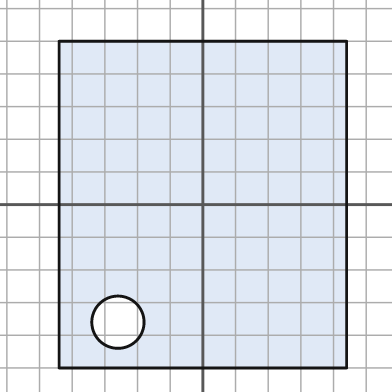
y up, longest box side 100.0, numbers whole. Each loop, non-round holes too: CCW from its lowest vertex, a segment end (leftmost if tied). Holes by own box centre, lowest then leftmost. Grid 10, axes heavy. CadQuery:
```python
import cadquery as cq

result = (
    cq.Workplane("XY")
    .moveTo(-44.0, -50.0)
    .lineTo(44.0, -50.0)
    .lineTo(44.0, 50.0)
    .lineTo(-44.0, 50.0)
    .close()
    .moveTo(-26.0, -36.0)
    .circle(8.0)
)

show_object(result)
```